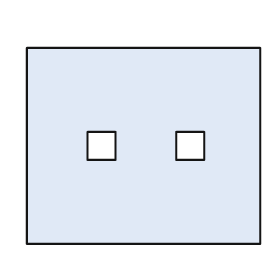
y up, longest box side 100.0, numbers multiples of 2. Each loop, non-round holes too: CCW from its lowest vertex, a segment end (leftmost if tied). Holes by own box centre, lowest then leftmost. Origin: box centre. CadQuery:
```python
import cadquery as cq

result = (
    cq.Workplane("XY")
    .moveTo(-50.0, -42.0)
    .lineTo(50.0, -42.0)
    .lineTo(50.0, 42.0)
    .lineTo(-50.0, 42.0)
    .close()
    .moveTo(-24.0, -6.0)
    .lineTo(-12.0, -6.0)
    .lineTo(-12.0, 6.0)
    .lineTo(-24.0, 6.0)
    .close()
    .moveTo(14.0, -6.0)
    .lineTo(26.0, -6.0)
    .lineTo(26.0, 6.0)
    .lineTo(14.0, 6.0)
    .close()
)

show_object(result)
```